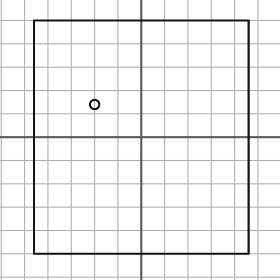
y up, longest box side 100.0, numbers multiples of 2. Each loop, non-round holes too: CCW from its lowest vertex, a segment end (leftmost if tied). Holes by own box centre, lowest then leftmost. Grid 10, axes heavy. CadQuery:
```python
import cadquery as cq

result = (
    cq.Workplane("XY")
    .moveTo(-46.0, -50.0)
    .lineTo(46.0, -50.0)
    .lineTo(46.0, 50.0)
    .lineTo(-46.0, 50.0)
    .close()
    .moveTo(-20.0, 14.0)
    .circle(2.0)
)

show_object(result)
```